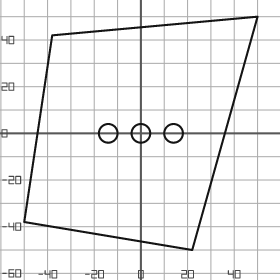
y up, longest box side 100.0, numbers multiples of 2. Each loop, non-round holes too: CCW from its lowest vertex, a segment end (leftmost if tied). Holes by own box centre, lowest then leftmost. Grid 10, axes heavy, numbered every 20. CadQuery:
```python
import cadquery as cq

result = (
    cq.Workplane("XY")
    .moveTo(22.0, -50.0)
    .lineTo(50.0, 50.0)
    .lineTo(-38.0, 42.0)
    .lineTo(-50.0, -38.0)
    .close()
    .moveTo(-14.0, 0.0)
    .circle(4.0)
    .moveTo(0.0, 0.0)
    .circle(4.0)
    .moveTo(14.0, 0.0)
    .circle(4.0)
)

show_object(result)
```